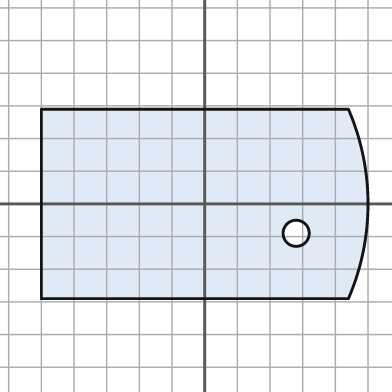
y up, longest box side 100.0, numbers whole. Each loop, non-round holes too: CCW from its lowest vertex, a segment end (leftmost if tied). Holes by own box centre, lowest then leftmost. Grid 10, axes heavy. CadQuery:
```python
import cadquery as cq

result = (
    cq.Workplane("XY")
    .moveTo(-50.0, -29.0)
    .lineTo(44.0, -29.0)
    .threePointArc((50.0, 0.0), (44.0, 29.0))
    .lineTo(-50.0, 29.0)
    .close()
    .moveTo(28.0, -9.0)
    .circle(4.0)
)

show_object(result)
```